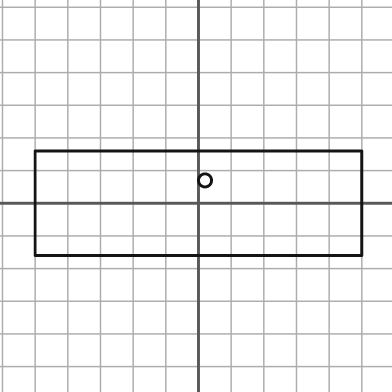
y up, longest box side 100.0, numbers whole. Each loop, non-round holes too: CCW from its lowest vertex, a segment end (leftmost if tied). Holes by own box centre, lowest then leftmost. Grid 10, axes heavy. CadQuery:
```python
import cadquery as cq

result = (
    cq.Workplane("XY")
    .moveTo(-50.0, -16.0)
    .lineTo(50.0, -16.0)
    .lineTo(50.0, 16.0)
    .lineTo(-50.0, 16.0)
    .close()
    .moveTo(2.0, 7.0)
    .circle(2.0)
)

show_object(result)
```